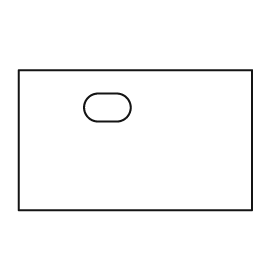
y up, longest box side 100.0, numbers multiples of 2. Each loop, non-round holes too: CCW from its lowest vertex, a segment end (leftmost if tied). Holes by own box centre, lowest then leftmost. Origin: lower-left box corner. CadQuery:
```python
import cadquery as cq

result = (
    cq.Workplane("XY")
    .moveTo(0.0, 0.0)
    .lineTo(100.0, 0.0)
    .lineTo(100.0, 60.0)
    .lineTo(0.0, 60.0)
    .close()
    .moveTo(34.0, 38.0)
    .lineTo(42.0, 38.0)
    .threePointArc((48.0, 44.0), (42.0, 50.0))
    .lineTo(34.0, 50.0)
    .threePointArc((28.0, 44.0), (34.0, 38.0))
    .close()
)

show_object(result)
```